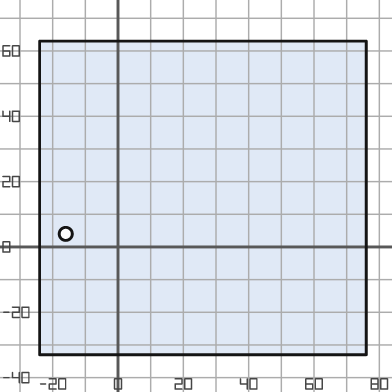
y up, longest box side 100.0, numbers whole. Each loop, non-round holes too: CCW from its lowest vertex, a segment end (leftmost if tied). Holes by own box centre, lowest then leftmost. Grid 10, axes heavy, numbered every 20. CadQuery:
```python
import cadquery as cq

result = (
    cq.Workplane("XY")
    .moveTo(-24.0, -33.0)
    .lineTo(76.0, -33.0)
    .lineTo(76.0, 63.0)
    .lineTo(-24.0, 63.0)
    .close()
    .moveTo(-16.0, 4.0)
    .circle(2.0)
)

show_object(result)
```